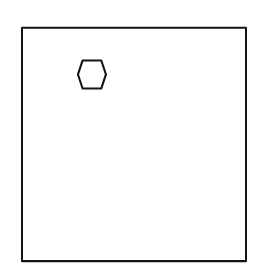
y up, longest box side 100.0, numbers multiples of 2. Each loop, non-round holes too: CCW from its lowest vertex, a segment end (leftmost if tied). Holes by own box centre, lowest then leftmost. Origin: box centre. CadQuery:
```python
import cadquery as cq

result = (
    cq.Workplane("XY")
    .moveTo(-48.0, -50.0)
    .lineTo(48.0, -50.0)
    .lineTo(48.0, 50.0)
    .lineTo(-48.0, 50.0)
    .close()
    .moveTo(-22.0, 24.0)
    .lineTo(-14.0, 24.0)
    .lineTo(-12.0, 30.0)
    .lineTo(-14.0, 36.0)
    .lineTo(-22.0, 36.0)
    .lineTo(-24.0, 30.0)
    .close()
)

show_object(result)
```